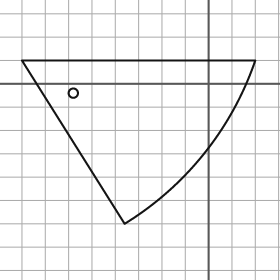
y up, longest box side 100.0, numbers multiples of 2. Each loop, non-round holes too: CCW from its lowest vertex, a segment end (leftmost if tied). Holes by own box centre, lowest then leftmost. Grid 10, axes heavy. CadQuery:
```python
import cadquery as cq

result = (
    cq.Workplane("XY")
    .moveTo(-36.0, -60.0)
    .threePointArc((-2.0, -30.0), (20.0, 10.0))
    .lineTo(-80.0, 10.0)
    .close()
    .moveTo(-58.0, -4.0)
    .circle(2.0)
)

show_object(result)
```